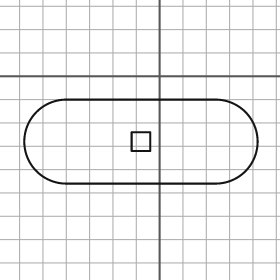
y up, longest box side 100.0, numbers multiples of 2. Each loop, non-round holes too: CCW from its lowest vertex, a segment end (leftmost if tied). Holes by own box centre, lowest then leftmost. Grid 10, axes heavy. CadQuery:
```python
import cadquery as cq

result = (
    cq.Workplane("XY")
    .moveTo(-40.0, -46.0)
    .lineTo(24.0, -46.0)
    .threePointArc((42.0, -28.0), (24.0, -10.0))
    .lineTo(-40.0, -10.0)
    .threePointArc((-58.0, -28.0), (-40.0, -46.0))
    .close()
    .moveTo(-12.0, -32.0)
    .lineTo(-4.0, -32.0)
    .lineTo(-4.0, -24.0)
    .lineTo(-12.0, -24.0)
    .close()
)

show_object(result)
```